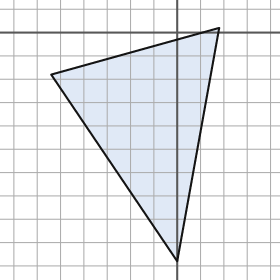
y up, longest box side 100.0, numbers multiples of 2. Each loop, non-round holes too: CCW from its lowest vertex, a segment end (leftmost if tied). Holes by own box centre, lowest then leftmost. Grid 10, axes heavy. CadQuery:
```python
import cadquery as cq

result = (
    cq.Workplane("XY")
    .moveTo(0.0, -98.0)
    .lineTo(18.0, 2.0)
    .lineTo(-54.0, -18.0)
    .close()
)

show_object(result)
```